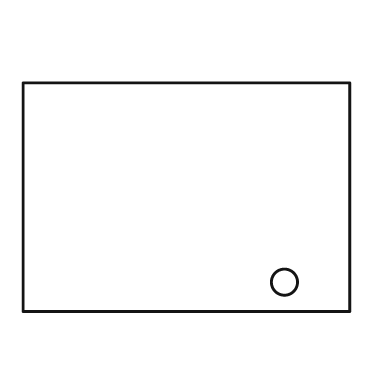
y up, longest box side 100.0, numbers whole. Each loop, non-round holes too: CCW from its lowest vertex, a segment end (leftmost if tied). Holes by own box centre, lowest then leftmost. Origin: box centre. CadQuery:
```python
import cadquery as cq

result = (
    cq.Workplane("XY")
    .moveTo(-50.0, -35.0)
    .lineTo(50.0, -35.0)
    .lineTo(50.0, 35.0)
    .lineTo(-50.0, 35.0)
    .close()
    .moveTo(30.0, -26.0)
    .circle(4.0)
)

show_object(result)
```